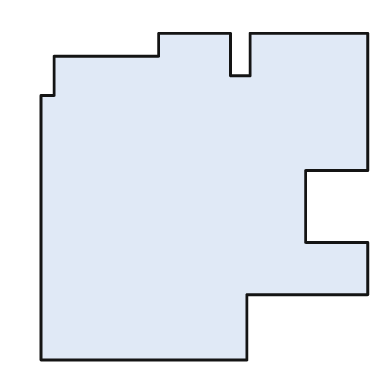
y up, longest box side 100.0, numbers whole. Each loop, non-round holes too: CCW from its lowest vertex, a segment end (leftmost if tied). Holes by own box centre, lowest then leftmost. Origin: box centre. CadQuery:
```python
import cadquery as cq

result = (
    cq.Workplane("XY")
    .moveTo(-50.0, -50.0)
    .lineTo(13.0, -50.0)
    .lineTo(13.0, -30.0)
    .lineTo(50.0, -30.0)
    .lineTo(50.0, -14.0)
    .lineTo(31.0, -14.0)
    .lineTo(31.0, 8.0)
    .lineTo(50.0, 8.0)
    .lineTo(50.0, 50.0)
    .lineTo(14.0, 50.0)
    .lineTo(14.0, 37.0)
    .lineTo(8.0, 37.0)
    .lineTo(8.0, 50.0)
    .lineTo(-14.0, 50.0)
    .lineTo(-14.0, 43.0)
    .lineTo(-46.0, 43.0)
    .lineTo(-46.0, 31.0)
    .lineTo(-50.0, 31.0)
    .close()
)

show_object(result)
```